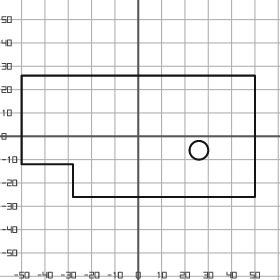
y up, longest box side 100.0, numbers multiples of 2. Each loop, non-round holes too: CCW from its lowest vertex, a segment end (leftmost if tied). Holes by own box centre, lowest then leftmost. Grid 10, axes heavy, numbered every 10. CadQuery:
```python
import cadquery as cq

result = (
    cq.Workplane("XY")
    .moveTo(-28.0, -26.0)
    .lineTo(50.0, -26.0)
    .lineTo(50.0, 26.0)
    .lineTo(-50.0, 26.0)
    .lineTo(-50.0, -12.0)
    .lineTo(-28.0, -12.0)
    .close()
    .moveTo(26.0, -6.0)
    .circle(4.0)
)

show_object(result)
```